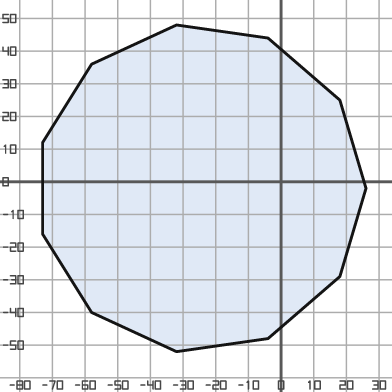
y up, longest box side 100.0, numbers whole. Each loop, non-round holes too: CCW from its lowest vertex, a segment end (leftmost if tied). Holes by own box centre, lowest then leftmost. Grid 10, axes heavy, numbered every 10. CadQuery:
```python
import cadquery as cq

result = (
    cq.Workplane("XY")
    .moveTo(-32.0, -52.0)
    .lineTo(-4.0, -48.0)
    .lineTo(18.0, -29.0)
    .lineTo(26.0, -2.0)
    .lineTo(18.0, 25.0)
    .lineTo(-4.0, 44.0)
    .lineTo(-32.0, 48.0)
    .lineTo(-58.0, 36.0)
    .lineTo(-73.0, 12.0)
    .lineTo(-73.0, -16.0)
    .lineTo(-58.0, -40.0)
    .close()
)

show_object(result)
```